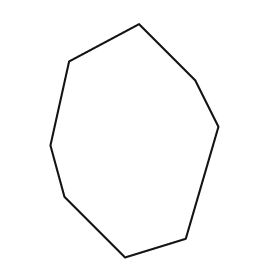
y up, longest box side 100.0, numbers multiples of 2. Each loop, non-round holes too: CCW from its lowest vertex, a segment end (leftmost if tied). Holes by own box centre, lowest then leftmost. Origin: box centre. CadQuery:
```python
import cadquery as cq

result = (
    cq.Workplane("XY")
    .moveTo(-4.0, -50.0)
    .lineTo(22.0, -42.0)
    .lineTo(36.0, 6.0)
    .lineTo(26.0, 26.0)
    .lineTo(2.0, 50.0)
    .lineTo(-28.0, 34.0)
    .lineTo(-36.0, -2.0)
    .lineTo(-30.0, -24.0)
    .close()
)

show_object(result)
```